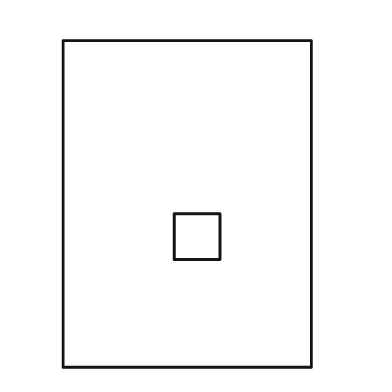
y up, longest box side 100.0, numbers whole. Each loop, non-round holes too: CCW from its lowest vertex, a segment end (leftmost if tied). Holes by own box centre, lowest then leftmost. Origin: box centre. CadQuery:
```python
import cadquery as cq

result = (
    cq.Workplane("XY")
    .moveTo(-38.0, -50.0)
    .lineTo(38.0, -50.0)
    .lineTo(38.0, 50.0)
    .lineTo(-38.0, 50.0)
    .close()
    .moveTo(-4.0, -17.0)
    .lineTo(10.0, -17.0)
    .lineTo(10.0, -3.0)
    .lineTo(-4.0, -3.0)
    .close()
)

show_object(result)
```